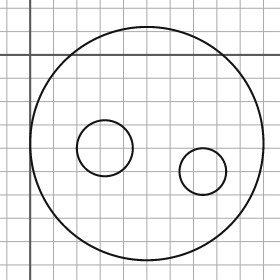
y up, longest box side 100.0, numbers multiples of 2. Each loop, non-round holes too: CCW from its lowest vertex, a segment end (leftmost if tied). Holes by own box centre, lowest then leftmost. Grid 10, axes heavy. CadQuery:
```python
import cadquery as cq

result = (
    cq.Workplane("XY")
    .moveTo(50.0, -38.0)
    .circle(50.0)
    .moveTo(74.0, -50.0)
    .circle(10.0)
    .moveTo(32.0, -40.0)
    .circle(12.0)
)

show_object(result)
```